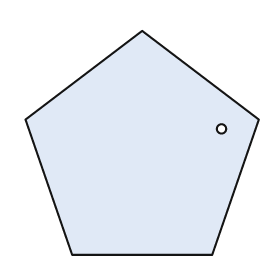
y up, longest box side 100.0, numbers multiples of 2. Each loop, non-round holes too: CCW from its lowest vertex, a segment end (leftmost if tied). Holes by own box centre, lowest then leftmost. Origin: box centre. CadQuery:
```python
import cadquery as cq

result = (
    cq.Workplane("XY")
    .moveTo(-30.0, -48.0)
    .lineTo(30.0, -48.0)
    .lineTo(50.0, 10.0)
    .lineTo(0.0, 48.0)
    .lineTo(-50.0, 10.0)
    .close()
    .moveTo(34.0, 6.0)
    .circle(2.0)
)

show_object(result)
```